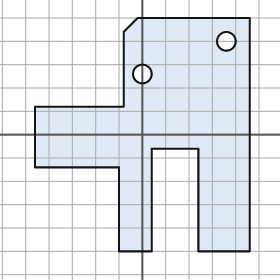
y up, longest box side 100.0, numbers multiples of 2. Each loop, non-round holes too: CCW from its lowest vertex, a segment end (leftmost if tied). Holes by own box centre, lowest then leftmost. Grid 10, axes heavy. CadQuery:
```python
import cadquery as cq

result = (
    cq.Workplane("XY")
    .moveTo(-10.0, -50.0)
    .lineTo(4.0, -50.0)
    .lineTo(4.0, -6.0)
    .lineTo(24.0, -6.0)
    .lineTo(24.0, -50.0)
    .lineTo(46.0, -50.0)
    .lineTo(46.0, 50.0)
    .lineTo(-2.0, 50.0)
    .lineTo(-8.0, 44.0)
    .lineTo(-8.0, 12.0)
    .lineTo(-46.0, 12.0)
    .lineTo(-46.0, -14.0)
    .lineTo(-10.0, -14.0)
    .close()
    .moveTo(0.0, 26.0)
    .circle(4.0)
    .moveTo(36.0, 40.0)
    .circle(4.0)
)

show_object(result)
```